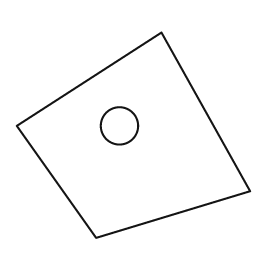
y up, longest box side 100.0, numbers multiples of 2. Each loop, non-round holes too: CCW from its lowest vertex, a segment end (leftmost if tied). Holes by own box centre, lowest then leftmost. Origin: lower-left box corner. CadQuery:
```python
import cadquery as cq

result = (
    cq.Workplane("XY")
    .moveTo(34.0, 0.0)
    .lineTo(100.0, 20.0)
    .lineTo(62.0, 88.0)
    .lineTo(0.0, 48.0)
    .close()
    .moveTo(44.0, 48.0)
    .circle(8.0)
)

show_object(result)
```